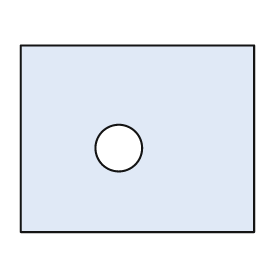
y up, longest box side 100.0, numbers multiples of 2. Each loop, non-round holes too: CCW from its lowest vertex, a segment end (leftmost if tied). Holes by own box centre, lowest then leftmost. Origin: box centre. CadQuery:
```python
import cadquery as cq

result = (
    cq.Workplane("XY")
    .moveTo(-50.0, -40.0)
    .lineTo(50.0, -40.0)
    .lineTo(50.0, 40.0)
    .lineTo(-50.0, 40.0)
    .close()
    .moveTo(-8.0, -4.0)
    .circle(10.0)
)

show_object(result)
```